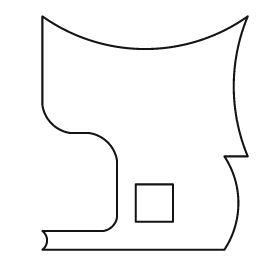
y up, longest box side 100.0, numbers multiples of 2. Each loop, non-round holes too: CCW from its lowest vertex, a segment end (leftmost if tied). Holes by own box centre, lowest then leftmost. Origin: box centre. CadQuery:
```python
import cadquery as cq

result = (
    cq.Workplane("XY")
    .moveTo(-44.0, -50.0)
    .lineTo(34.0, -50.0)
    .threePointArc((40.0, -30.0), (34.0, -10.0))
    .lineTo(44.0, -10.0)
    .threePointArc((38.0, 20.0), (44.0, 50.0))
    .threePointArc((0.0, 36.0), (-44.0, 50.0))
    .lineTo(-44.0, 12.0)
    .threePointArc((-40.0, 4.0), (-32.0, 0.0))
    .lineTo(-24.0, 0.0)
    .threePointArc((-16.0, -4.0), (-12.0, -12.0))
    .lineTo(-12.0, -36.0)
    .threePointArc((-14.0, -40.0), (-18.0, -42.0))
    .lineTo(-44.0, -42.0)
    .threePointArc((-42.0, -46.0), (-44.0, -50.0))
    .close()
    .moveTo(-4.0, -38.0)
    .lineTo(12.0, -38.0)
    .lineTo(12.0, -22.0)
    .lineTo(-4.0, -22.0)
    .close()
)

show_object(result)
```